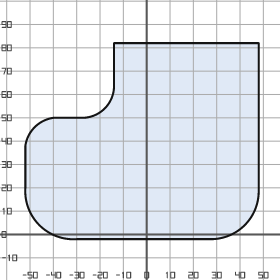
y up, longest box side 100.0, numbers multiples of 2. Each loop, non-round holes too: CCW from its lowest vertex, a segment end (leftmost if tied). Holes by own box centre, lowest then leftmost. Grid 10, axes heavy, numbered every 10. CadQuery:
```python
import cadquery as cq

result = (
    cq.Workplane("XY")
    .moveTo(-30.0, -2.0)
    .lineTo(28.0, -2.0)
    .threePointArc((42.0, 4.0), (48.0, 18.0))
    .lineTo(48.0, 82.0)
    .lineTo(-14.0, 82.0)
    .lineTo(-14.0, 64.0)
    .threePointArc((-18.0, 54.0), (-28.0, 50.0))
    .lineTo(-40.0, 50.0)
    .threePointArc((-48.0, 46.0), (-52.0, 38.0))
    .lineTo(-52.0, 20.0)
    .threePointArc((-46.0, 4.0), (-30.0, -2.0))
    .close()
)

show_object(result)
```